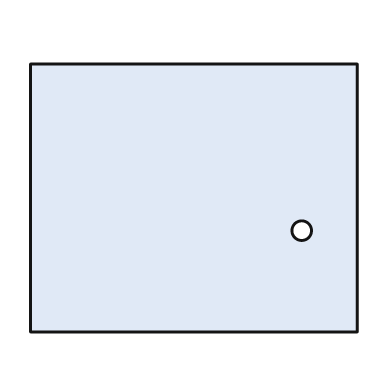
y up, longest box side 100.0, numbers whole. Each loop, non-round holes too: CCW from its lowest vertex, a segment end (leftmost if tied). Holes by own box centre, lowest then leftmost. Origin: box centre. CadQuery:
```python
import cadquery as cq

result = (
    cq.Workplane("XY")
    .moveTo(-50.0, -41.0)
    .lineTo(50.0, -41.0)
    .lineTo(50.0, 41.0)
    .lineTo(-50.0, 41.0)
    .close()
    .moveTo(33.0, -10.0)
    .circle(3.0)
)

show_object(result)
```